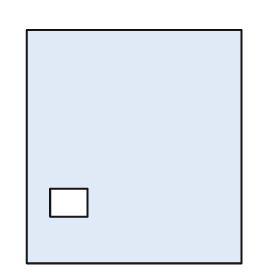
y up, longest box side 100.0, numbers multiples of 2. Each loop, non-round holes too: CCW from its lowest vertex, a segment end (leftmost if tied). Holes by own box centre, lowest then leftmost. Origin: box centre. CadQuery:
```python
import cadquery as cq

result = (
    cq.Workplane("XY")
    .moveTo(-46.0, -50.0)
    .lineTo(46.0, -50.0)
    .lineTo(46.0, 50.0)
    .lineTo(-46.0, 50.0)
    .close()
    .moveTo(-36.0, -30.0)
    .lineTo(-20.0, -30.0)
    .lineTo(-20.0, -18.0)
    .lineTo(-36.0, -18.0)
    .close()
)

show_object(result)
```